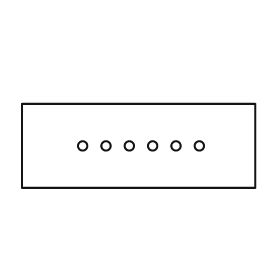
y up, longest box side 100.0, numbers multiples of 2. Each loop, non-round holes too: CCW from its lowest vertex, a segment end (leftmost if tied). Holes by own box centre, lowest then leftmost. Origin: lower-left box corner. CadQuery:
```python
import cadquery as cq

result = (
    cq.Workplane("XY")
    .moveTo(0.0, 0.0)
    .lineTo(100.0, 0.0)
    .lineTo(100.0, 36.0)
    .lineTo(0.0, 36.0)
    .close()
    .moveTo(26.0, 18.0)
    .circle(2.0)
    .moveTo(36.0, 18.0)
    .circle(2.0)
    .moveTo(46.0, 18.0)
    .circle(2.0)
    .moveTo(56.0, 18.0)
    .circle(2.0)
    .moveTo(66.0, 18.0)
    .circle(2.0)
    .moveTo(76.0, 18.0)
    .circle(2.0)
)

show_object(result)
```